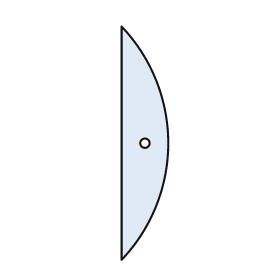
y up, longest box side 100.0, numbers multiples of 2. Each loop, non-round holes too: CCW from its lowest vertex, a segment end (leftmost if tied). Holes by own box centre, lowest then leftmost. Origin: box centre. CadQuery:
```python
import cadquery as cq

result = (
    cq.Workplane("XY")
    .moveTo(-10.0, -50.0)
    .threePointArc((10.0, 0.0), (-10.0, 50.0))
    .close()
    .moveTo(0.0, 0.0)
    .circle(2.0)
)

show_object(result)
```